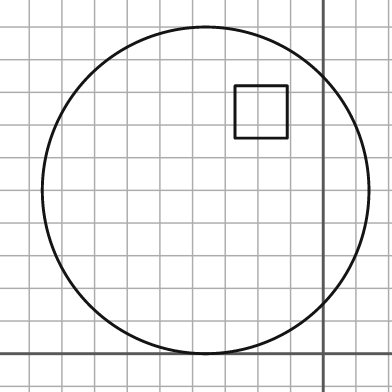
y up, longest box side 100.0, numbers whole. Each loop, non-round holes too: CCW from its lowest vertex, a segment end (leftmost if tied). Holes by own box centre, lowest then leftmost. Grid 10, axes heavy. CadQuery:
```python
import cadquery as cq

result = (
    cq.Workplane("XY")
    .moveTo(-36.0, 50.0)
    .circle(50.0)
    .moveTo(-27.0, 66.0)
    .lineTo(-11.0, 66.0)
    .lineTo(-11.0, 82.0)
    .lineTo(-27.0, 82.0)
    .close()
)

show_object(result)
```